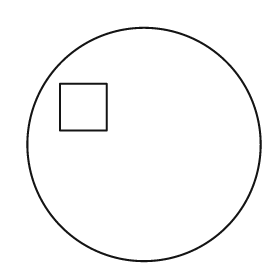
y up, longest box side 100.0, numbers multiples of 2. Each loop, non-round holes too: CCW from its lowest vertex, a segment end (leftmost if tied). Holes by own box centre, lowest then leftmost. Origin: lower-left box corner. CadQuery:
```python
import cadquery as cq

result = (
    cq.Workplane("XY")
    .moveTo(50.0, 50.0)
    .circle(50.0)
    .moveTo(14.0, 56.0)
    .lineTo(34.0, 56.0)
    .lineTo(34.0, 76.0)
    .lineTo(14.0, 76.0)
    .close()
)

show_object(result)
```